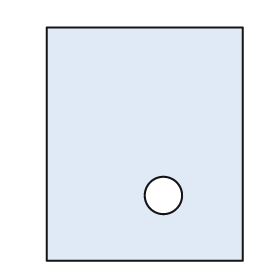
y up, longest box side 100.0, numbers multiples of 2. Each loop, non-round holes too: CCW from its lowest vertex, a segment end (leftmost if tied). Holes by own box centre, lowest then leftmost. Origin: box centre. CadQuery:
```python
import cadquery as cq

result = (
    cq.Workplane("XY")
    .moveTo(-42.0, -50.0)
    .lineTo(42.0, -50.0)
    .lineTo(42.0, 50.0)
    .lineTo(-42.0, 50.0)
    .close()
    .moveTo(8.0, -22.0)
    .circle(8.0)
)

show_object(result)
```